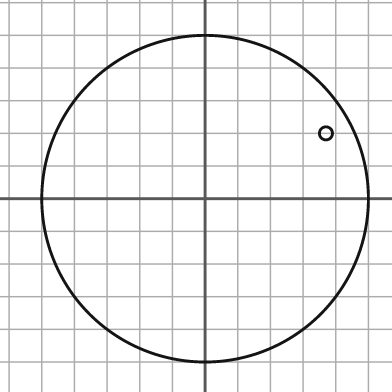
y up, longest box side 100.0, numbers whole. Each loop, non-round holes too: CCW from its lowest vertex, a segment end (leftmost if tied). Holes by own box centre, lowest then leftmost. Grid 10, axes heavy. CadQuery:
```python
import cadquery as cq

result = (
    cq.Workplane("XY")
    .moveTo(0.0, 0.0)
    .circle(50.0)
    .moveTo(37.0, 20.0)
    .circle(2.0)
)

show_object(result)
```